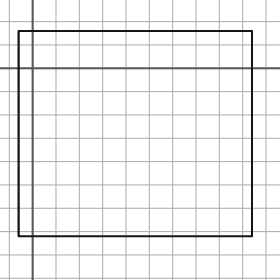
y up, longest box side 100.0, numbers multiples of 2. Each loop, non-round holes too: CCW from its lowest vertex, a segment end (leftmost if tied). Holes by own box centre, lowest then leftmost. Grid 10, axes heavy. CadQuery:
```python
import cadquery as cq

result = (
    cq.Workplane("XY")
    .moveTo(-6.0, -72.0)
    .lineTo(94.0, -72.0)
    .lineTo(94.0, 16.0)
    .lineTo(-6.0, 16.0)
    .close()
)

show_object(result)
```